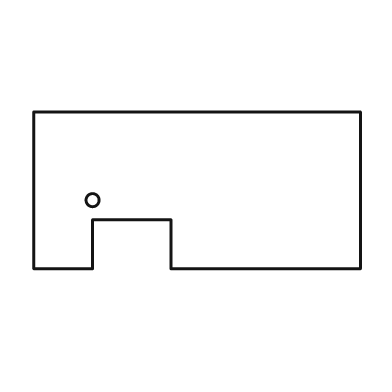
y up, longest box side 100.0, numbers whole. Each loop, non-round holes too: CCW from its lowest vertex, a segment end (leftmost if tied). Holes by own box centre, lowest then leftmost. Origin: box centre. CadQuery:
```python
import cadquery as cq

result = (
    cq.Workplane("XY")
    .moveTo(-50.0, -24.0)
    .lineTo(-32.0, -24.0)
    .lineTo(-32.0, -9.0)
    .lineTo(-8.0, -9.0)
    .lineTo(-8.0, -24.0)
    .lineTo(50.0, -24.0)
    .lineTo(50.0, 24.0)
    .lineTo(-50.0, 24.0)
    .close()
    .moveTo(-32.0, -3.0)
    .circle(2.0)
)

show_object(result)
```